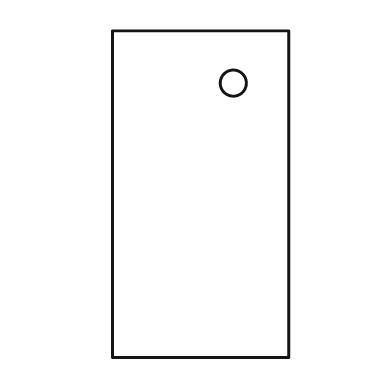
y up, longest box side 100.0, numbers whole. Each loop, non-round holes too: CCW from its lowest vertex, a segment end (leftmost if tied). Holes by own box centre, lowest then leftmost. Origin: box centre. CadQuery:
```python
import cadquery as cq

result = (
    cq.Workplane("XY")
    .moveTo(-27.0, -50.0)
    .lineTo(27.0, -50.0)
    .lineTo(27.0, 50.0)
    .lineTo(-27.0, 50.0)
    .close()
    .moveTo(10.0, 34.0)
    .circle(4.0)
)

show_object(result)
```